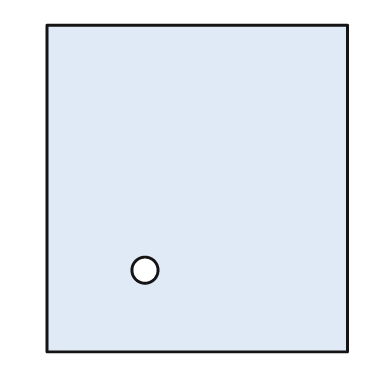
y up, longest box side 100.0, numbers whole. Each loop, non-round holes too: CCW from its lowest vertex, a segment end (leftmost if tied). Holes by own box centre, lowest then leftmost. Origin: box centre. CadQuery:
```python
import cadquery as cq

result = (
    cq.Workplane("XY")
    .moveTo(-46.0, -50.0)
    .lineTo(46.0, -50.0)
    .lineTo(46.0, 50.0)
    .lineTo(-46.0, 50.0)
    .close()
    .moveTo(-16.0, -25.0)
    .circle(4.0)
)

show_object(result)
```